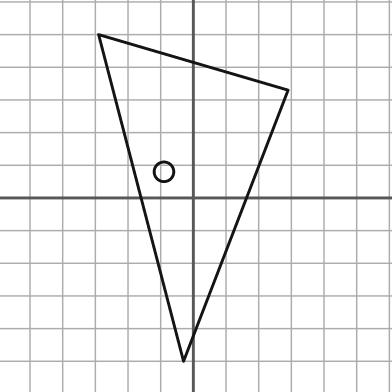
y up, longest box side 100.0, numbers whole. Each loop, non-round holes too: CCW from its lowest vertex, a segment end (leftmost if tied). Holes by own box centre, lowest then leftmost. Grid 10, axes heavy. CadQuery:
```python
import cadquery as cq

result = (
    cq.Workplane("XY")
    .moveTo(-3.0, -50.0)
    .lineTo(29.0, 33.0)
    .lineTo(-29.0, 50.0)
    .close()
    .moveTo(-9.0, 8.0)
    .circle(3.0)
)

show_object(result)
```